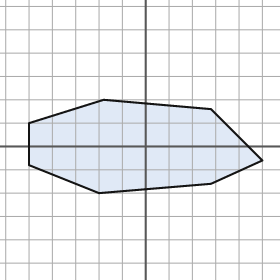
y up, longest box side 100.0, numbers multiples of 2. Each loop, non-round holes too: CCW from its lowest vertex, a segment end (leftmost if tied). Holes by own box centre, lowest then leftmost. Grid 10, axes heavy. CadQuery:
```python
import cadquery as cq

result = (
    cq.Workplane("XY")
    .moveTo(-20.0, -20.0)
    .lineTo(28.0, -16.0)
    .lineTo(50.0, -6.0)
    .lineTo(28.0, 16.0)
    .lineTo(-18.0, 20.0)
    .lineTo(-50.0, 10.0)
    .lineTo(-50.0, -8.0)
    .close()
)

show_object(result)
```